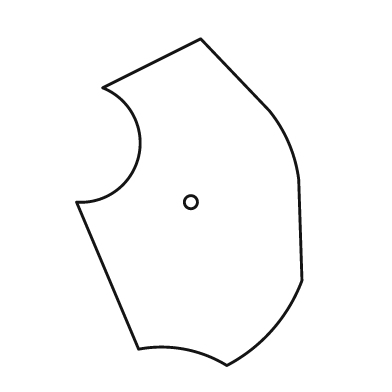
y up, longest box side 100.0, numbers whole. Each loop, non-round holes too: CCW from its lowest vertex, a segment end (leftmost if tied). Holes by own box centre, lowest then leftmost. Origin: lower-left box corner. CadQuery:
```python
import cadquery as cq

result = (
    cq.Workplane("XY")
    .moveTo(46.0, 0.0)
    .threePointArc((60.0, 11.0), (69.0, 26.0))
    .lineTo(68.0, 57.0)
    .threePointArc((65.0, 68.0), (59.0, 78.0))
    .lineTo(38.0, 100.0)
    .lineTo(8.0, 85.0)
    .threePointArc((19.0, 64.0), (0.0, 50.0))
    .lineTo(19.0, 5.0)
    .threePointArc((33.0, 5.0), (46.0, 0.0))
    .close()
    .moveTo(35.0, 50.0)
    .circle(2.0)
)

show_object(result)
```